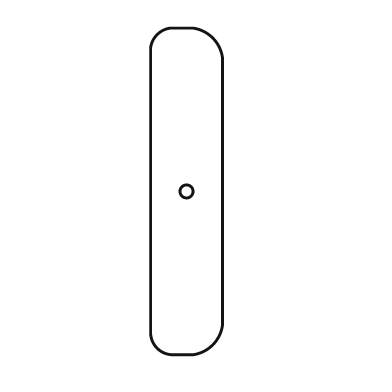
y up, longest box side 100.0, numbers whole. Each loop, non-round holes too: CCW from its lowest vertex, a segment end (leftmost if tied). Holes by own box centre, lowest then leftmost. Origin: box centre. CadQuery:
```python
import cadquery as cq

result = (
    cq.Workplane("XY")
    .moveTo(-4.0, -50.0)
    .lineTo(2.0, -50.0)
    .threePointArc((8.0, -47.0), (11.0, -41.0))
    .lineTo(11.0, 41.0)
    .threePointArc((8.0, 47.0), (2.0, 50.0))
    .lineTo(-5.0, 50.0)
    .threePointArc((-9.0, 48.0), (-11.0, 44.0))
    .lineTo(-11.0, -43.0)
    .threePointArc((-9.0, -48.0), (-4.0, -50.0))
    .close()
    .moveTo(0.0, 0.0)
    .circle(2.0)
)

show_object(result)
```